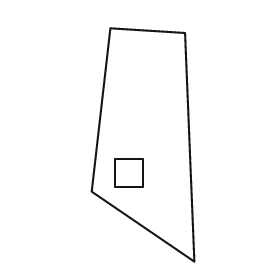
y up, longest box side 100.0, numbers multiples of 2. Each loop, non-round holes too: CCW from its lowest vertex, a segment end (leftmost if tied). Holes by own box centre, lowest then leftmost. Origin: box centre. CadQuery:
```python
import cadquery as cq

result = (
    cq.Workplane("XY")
    .moveTo(22.0, -50.0)
    .lineTo(18.0, 48.0)
    .lineTo(-14.0, 50.0)
    .lineTo(-22.0, -20.0)
    .close()
    .moveTo(-12.0, -18.0)
    .lineTo(0.0, -18.0)
    .lineTo(0.0, -6.0)
    .lineTo(-12.0, -6.0)
    .close()
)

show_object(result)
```